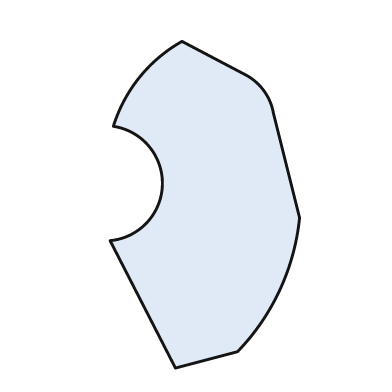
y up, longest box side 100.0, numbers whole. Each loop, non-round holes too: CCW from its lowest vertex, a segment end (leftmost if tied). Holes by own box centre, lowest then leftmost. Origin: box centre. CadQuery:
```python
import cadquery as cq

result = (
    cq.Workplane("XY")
    .moveTo(-9.0, -50.0)
    .lineTo(10.0, -45.0)
    .threePointArc((23.0, -26.0), (29.0, -4.0))
    .lineTo(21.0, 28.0)
    .threePointArc((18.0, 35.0), (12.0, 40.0))
    .lineTo(-7.0, 50.0)
    .threePointArc((-20.0, 39.0), (-28.0, 24.0))
    .threePointArc((-13.0, 6.0), (-29.0, -11.0))
    .close()
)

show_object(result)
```